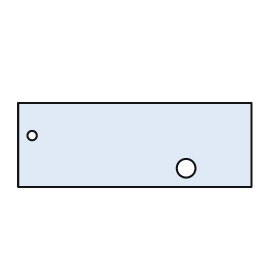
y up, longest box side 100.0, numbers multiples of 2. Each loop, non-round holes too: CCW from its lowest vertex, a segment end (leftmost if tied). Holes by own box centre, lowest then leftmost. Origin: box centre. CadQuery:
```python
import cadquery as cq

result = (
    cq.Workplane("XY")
    .moveTo(-50.0, -18.0)
    .lineTo(50.0, -18.0)
    .lineTo(50.0, 18.0)
    .lineTo(-50.0, 18.0)
    .close()
    .moveTo(22.0, -10.0)
    .circle(4.0)
    .moveTo(-44.0, 4.0)
    .circle(2.0)
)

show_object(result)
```